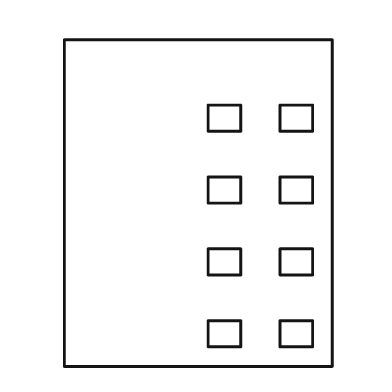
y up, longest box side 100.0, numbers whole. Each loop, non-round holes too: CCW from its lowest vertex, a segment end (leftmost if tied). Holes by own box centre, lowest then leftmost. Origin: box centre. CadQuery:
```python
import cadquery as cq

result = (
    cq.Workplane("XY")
    .moveTo(-41.0, -50.0)
    .lineTo(41.0, -50.0)
    .lineTo(41.0, 50.0)
    .lineTo(-41.0, 50.0)
    .close()
    .moveTo(3.0, -44.0)
    .lineTo(13.0, -44.0)
    .lineTo(13.0, -36.0)
    .lineTo(3.0, -36.0)
    .close()
    .moveTo(25.0, -44.0)
    .lineTo(35.0, -44.0)
    .lineTo(35.0, -36.0)
    .lineTo(25.0, -36.0)
    .close()
    .moveTo(3.0, -22.0)
    .lineTo(13.0, -22.0)
    .lineTo(13.0, -14.0)
    .lineTo(3.0, -14.0)
    .close()
    .moveTo(25.0, -22.0)
    .lineTo(35.0, -22.0)
    .lineTo(35.0, -14.0)
    .lineTo(25.0, -14.0)
    .close()
    .moveTo(3.0, 0.0)
    .lineTo(13.0, 0.0)
    .lineTo(13.0, 8.0)
    .lineTo(3.0, 8.0)
    .close()
    .moveTo(25.0, 0.0)
    .lineTo(35.0, 0.0)
    .lineTo(35.0, 8.0)
    .lineTo(25.0, 8.0)
    .close()
    .moveTo(3.0, 22.0)
    .lineTo(13.0, 22.0)
    .lineTo(13.0, 30.0)
    .lineTo(3.0, 30.0)
    .close()
    .moveTo(25.0, 22.0)
    .lineTo(35.0, 22.0)
    .lineTo(35.0, 30.0)
    .lineTo(25.0, 30.0)
    .close()
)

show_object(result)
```